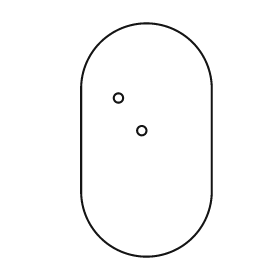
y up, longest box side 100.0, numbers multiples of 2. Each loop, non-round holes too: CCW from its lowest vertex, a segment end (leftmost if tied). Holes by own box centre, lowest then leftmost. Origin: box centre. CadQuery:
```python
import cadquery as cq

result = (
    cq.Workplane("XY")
    .moveTo(-28.0, -22.0)
    .threePointArc((0.0, -50.0), (28.0, -22.0))
    .lineTo(28.0, 22.0)
    .threePointArc((0.0, 50.0), (-28.0, 22.0))
    .close()
    .moveTo(-2.0, 4.0)
    .circle(2.0)
    .moveTo(-12.0, 18.0)
    .circle(2.0)
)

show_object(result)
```